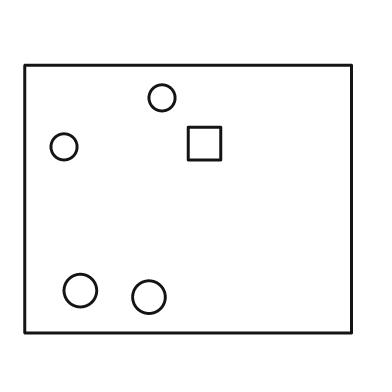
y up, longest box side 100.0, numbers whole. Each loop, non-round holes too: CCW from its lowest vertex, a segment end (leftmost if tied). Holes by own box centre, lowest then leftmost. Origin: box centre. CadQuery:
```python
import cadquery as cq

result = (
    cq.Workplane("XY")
    .moveTo(-50.0, -41.0)
    .lineTo(50.0, -41.0)
    .lineTo(50.0, 41.0)
    .lineTo(-50.0, 41.0)
    .close()
    .moveTo(-12.0, -30.0)
    .circle(5.0)
    .moveTo(-33.0, -28.0)
    .circle(5.0)
    .moveTo(-38.0, 16.0)
    .circle(4.0)
    .moveTo(0.0, 12.0)
    .lineTo(10.0, 12.0)
    .lineTo(10.0, 22.0)
    .lineTo(0.0, 22.0)
    .close()
    .moveTo(-8.0, 31.0)
    .circle(4.0)
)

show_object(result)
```